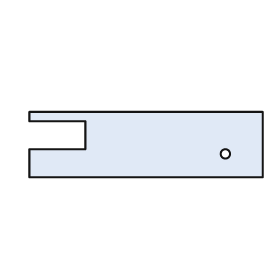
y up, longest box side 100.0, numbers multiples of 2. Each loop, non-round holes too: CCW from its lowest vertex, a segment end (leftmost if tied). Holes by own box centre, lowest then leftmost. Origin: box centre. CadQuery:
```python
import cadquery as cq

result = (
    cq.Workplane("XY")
    .moveTo(-50.0, -14.0)
    .lineTo(50.0, -14.0)
    .lineTo(50.0, 14.0)
    .lineTo(-50.0, 14.0)
    .lineTo(-50.0, 10.0)
    .lineTo(-26.0, 10.0)
    .lineTo(-26.0, -2.0)
    .lineTo(-50.0, -2.0)
    .close()
    .moveTo(34.0, -4.0)
    .circle(2.0)
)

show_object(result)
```